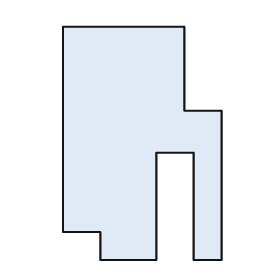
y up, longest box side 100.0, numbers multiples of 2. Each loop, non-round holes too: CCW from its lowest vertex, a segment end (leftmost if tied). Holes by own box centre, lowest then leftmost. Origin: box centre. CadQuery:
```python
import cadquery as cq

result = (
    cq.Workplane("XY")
    .moveTo(-18.0, -50.0)
    .lineTo(6.0, -50.0)
    .lineTo(6.0, -4.0)
    .lineTo(22.0, -4.0)
    .lineTo(22.0, -50.0)
    .lineTo(34.0, -50.0)
    .lineTo(34.0, 14.0)
    .lineTo(18.0, 14.0)
    .lineTo(18.0, 50.0)
    .lineTo(-34.0, 50.0)
    .lineTo(-34.0, -38.0)
    .lineTo(-18.0, -38.0)
    .close()
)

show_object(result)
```